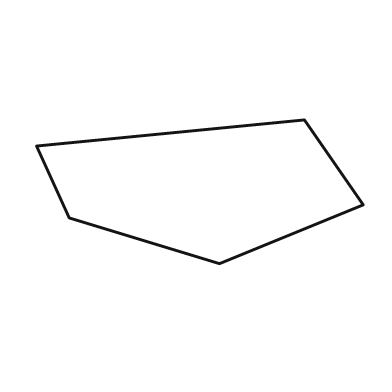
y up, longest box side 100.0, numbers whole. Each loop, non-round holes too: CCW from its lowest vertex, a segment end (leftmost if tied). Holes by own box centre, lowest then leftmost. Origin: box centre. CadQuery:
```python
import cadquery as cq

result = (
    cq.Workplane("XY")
    .moveTo(6.0, -22.0)
    .lineTo(50.0, -4.0)
    .lineTo(32.0, 22.0)
    .lineTo(-50.0, 14.0)
    .lineTo(-40.0, -8.0)
    .close()
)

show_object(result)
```